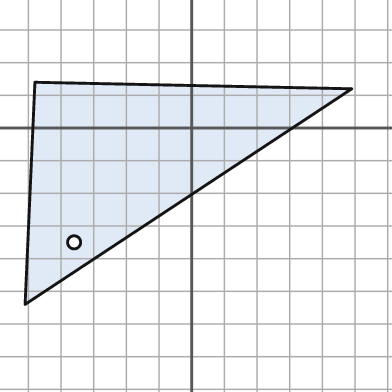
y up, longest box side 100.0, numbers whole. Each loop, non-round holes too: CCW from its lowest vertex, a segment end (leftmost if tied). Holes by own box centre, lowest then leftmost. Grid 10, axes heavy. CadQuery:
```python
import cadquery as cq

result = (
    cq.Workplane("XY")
    .moveTo(-51.0, -54.0)
    .lineTo(49.0, 12.0)
    .lineTo(-48.0, 14.0)
    .close()
    .moveTo(-36.0, -35.0)
    .circle(2.0)
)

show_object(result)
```